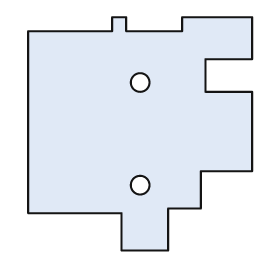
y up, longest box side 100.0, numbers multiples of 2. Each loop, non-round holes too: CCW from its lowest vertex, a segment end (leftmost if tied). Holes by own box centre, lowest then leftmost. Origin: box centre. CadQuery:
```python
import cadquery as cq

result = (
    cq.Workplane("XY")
    .moveTo(-8.0, -50.0)
    .lineTo(12.0, -50.0)
    .lineTo(12.0, -32.0)
    .lineTo(26.0, -32.0)
    .lineTo(26.0, -16.0)
    .lineTo(48.0, -16.0)
    .lineTo(48.0, 18.0)
    .lineTo(28.0, 18.0)
    .lineTo(28.0, 32.0)
    .lineTo(48.0, 32.0)
    .lineTo(48.0, 50.0)
    .lineTo(18.0, 50.0)
    .lineTo(18.0, 44.0)
    .lineTo(-6.0, 44.0)
    .lineTo(-6.0, 50.0)
    .lineTo(-12.0, 50.0)
    .lineTo(-12.0, 44.0)
    .lineTo(-48.0, 44.0)
    .lineTo(-48.0, -34.0)
    .lineTo(-8.0, -34.0)
    .close()
    .moveTo(0.0, -22.0)
    .circle(4.0)
    .moveTo(0.0, 22.0)
    .circle(4.0)
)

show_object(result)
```